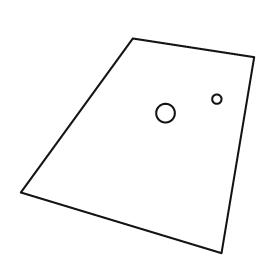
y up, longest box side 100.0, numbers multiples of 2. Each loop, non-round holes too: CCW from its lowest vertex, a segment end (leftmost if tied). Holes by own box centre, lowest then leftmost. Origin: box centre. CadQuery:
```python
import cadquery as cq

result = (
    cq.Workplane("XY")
    .moveTo(36.0, -46.0)
    .lineTo(50.0, 38.0)
    .lineTo(-2.0, 46.0)
    .lineTo(-50.0, -20.0)
    .close()
    .moveTo(12.0, 14.0)
    .circle(4.0)
    .moveTo(34.0, 20.0)
    .circle(2.0)
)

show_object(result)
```